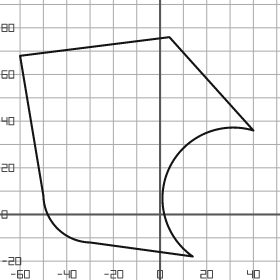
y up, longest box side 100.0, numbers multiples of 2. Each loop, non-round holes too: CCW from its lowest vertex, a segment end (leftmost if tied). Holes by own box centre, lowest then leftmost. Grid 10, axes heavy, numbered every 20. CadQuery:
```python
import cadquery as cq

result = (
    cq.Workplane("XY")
    .moveTo(14.0, -18.0)
    .threePointArc((4.0, 20.0), (40.0, 36.0))
    .lineTo(4.0, 76.0)
    .lineTo(-60.0, 68.0)
    .lineTo(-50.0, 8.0)
    .threePointArc((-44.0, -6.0), (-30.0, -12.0))
    .close()
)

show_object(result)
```